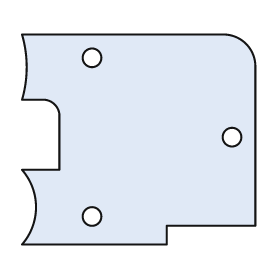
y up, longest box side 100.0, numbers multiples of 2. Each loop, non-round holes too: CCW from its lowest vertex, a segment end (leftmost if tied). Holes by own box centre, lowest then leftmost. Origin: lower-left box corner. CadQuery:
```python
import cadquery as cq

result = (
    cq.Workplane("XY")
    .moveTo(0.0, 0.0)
    .lineTo(62.0, 0.0)
    .lineTo(62.0, 8.0)
    .lineTo(100.0, 8.0)
    .lineTo(100.0, 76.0)
    .threePointArc((96.0, 86.0), (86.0, 90.0))
    .lineTo(0.0, 90.0)
    .threePointArc((2.0, 76.0), (0.0, 62.0))
    .lineTo(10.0, 62.0)
    .threePointArc((14.0, 60.0), (16.0, 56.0))
    .lineTo(16.0, 32.0)
    .lineTo(0.0, 32.0)
    .threePointArc((6.0, 16.0), (0.0, 0.0))
    .close()
    .moveTo(30.0, 12.0)
    .circle(4.0)
    .moveTo(90.0, 46.0)
    .circle(4.0)
    .moveTo(30.0, 80.0)
    .circle(4.0)
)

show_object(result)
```